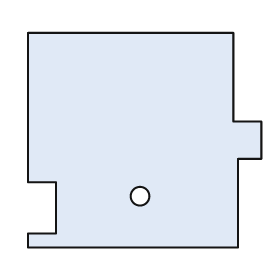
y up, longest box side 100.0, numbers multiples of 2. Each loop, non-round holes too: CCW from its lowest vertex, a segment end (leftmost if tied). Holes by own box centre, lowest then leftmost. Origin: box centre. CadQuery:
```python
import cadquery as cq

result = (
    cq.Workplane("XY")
    .moveTo(-50.0, -46.0)
    .lineTo(40.0, -46.0)
    .lineTo(40.0, -8.0)
    .lineTo(50.0, -8.0)
    .lineTo(50.0, 8.0)
    .lineTo(38.0, 8.0)
    .lineTo(38.0, 46.0)
    .lineTo(-50.0, 46.0)
    .lineTo(-50.0, -18.0)
    .lineTo(-38.0, -18.0)
    .lineTo(-38.0, -40.0)
    .lineTo(-50.0, -40.0)
    .close()
    .moveTo(-2.0, -24.0)
    .circle(4.0)
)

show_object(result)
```